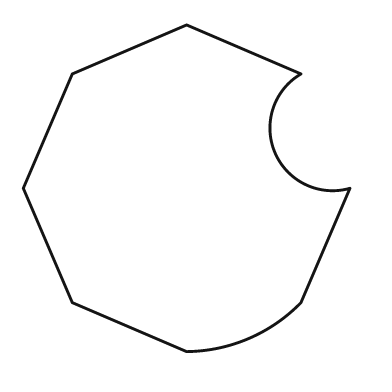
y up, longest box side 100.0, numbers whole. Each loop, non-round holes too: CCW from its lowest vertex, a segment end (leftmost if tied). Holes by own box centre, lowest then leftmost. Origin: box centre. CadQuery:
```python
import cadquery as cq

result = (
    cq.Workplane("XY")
    .moveTo(0.0, -50.0)
    .threePointArc((19.0, -46.0), (35.0, -35.0))
    .lineTo(50.0, 0.0)
    .threePointArc((27.0, 11.0), (35.0, 35.0))
    .lineTo(0.0, 50.0)
    .lineTo(-35.0, 35.0)
    .lineTo(-50.0, 0.0)
    .lineTo(-35.0, -35.0)
    .close()
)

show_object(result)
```